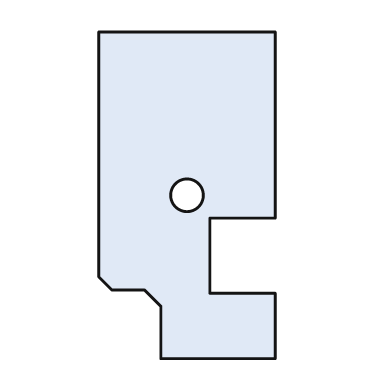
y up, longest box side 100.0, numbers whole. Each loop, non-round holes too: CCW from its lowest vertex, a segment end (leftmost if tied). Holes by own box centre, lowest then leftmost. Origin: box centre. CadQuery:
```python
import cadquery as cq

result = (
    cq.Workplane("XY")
    .moveTo(-8.0, -50.0)
    .lineTo(27.0, -50.0)
    .lineTo(27.0, -30.0)
    .lineTo(7.0, -30.0)
    .lineTo(7.0, -7.0)
    .lineTo(27.0, -7.0)
    .lineTo(27.0, 50.0)
    .lineTo(-27.0, 50.0)
    .lineTo(-27.0, -25.0)
    .lineTo(-23.0, -29.0)
    .lineTo(-13.0, -29.0)
    .lineTo(-8.0, -34.0)
    .close()
    .moveTo(0.0, 0.0)
    .circle(5.0)
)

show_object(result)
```